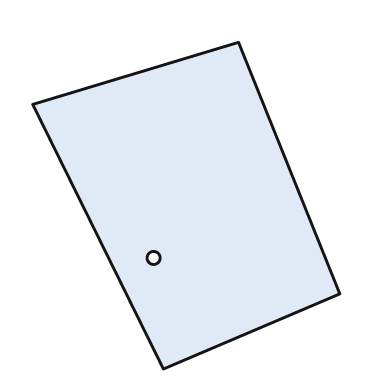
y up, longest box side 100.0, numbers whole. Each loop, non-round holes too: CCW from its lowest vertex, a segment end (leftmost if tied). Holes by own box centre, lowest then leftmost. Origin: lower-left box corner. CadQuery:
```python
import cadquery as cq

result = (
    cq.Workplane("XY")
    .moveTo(40.0, 0.0)
    .lineTo(94.0, 23.0)
    .lineTo(63.0, 100.0)
    .lineTo(0.0, 81.0)
    .close()
    .moveTo(37.0, 34.0)
    .circle(2.0)
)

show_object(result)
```